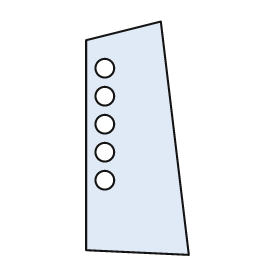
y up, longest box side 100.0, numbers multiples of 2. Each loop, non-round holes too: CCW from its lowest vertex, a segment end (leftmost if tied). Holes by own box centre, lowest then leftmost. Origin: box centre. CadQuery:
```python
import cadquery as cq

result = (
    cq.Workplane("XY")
    .moveTo(22.0, -50.0)
    .lineTo(10.0, 50.0)
    .lineTo(-22.0, 42.0)
    .lineTo(-22.0, -48.0)
    .close()
    .moveTo(-14.0, -18.0)
    .circle(4.0)
    .moveTo(-14.0, -6.0)
    .circle(4.0)
    .moveTo(-14.0, 6.0)
    .circle(4.0)
    .moveTo(-14.0, 18.0)
    .circle(4.0)
    .moveTo(-14.0, 30.0)
    .circle(4.0)
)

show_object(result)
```